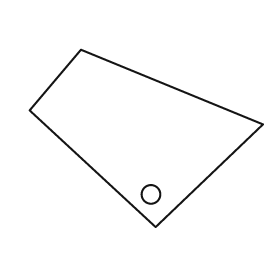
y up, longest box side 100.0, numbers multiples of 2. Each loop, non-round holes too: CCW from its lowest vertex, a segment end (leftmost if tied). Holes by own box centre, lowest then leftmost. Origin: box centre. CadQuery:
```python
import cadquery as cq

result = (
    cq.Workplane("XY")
    .moveTo(4.0, -38.0)
    .lineTo(50.0, 6.0)
    .lineTo(-28.0, 38.0)
    .lineTo(-50.0, 12.0)
    .close()
    .moveTo(2.0, -24.0)
    .circle(4.0)
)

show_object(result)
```